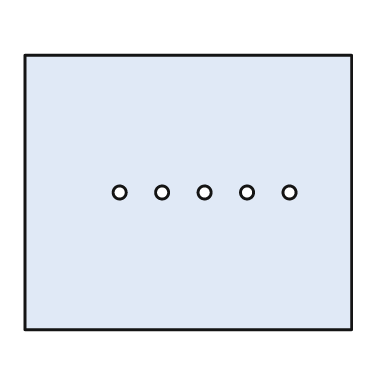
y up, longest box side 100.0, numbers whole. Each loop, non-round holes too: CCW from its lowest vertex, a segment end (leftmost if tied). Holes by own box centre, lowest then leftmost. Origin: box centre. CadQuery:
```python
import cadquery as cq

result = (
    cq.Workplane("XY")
    .moveTo(-50.0, -42.0)
    .lineTo(50.0, -42.0)
    .lineTo(50.0, 42.0)
    .lineTo(-50.0, 42.0)
    .close()
    .moveTo(-21.0, 0.0)
    .circle(2.0)
    .moveTo(-8.0, 0.0)
    .circle(2.0)
    .moveTo(5.0, 0.0)
    .circle(2.0)
    .moveTo(18.0, 0.0)
    .circle(2.0)
    .moveTo(31.0, 0.0)
    .circle(2.0)
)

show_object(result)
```